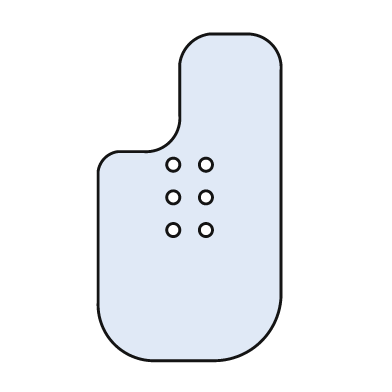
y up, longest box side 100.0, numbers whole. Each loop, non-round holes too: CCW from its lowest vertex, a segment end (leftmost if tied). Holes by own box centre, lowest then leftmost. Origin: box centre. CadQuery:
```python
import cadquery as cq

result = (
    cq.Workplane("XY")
    .moveTo(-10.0, -50.0)
    .lineTo(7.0, -50.0)
    .threePointArc((22.0, -44.0), (28.0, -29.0))
    .lineTo(28.0, 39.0)
    .threePointArc((25.0, 47.0), (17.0, 50.0))
    .lineTo(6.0, 50.0)
    .threePointArc((0.0, 47.0), (-3.0, 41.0))
    .lineTo(-3.0, 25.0)
    .threePointArc((-6.0, 17.0), (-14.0, 14.0))
    .lineTo(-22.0, 14.0)
    .threePointArc((-26.0, 12.0), (-28.0, 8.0))
    .lineTo(-28.0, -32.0)
    .threePointArc((-23.0, -45.0), (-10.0, -50.0))
    .close()
    .moveTo(-5.0, -10.0)
    .circle(2.0)
    .moveTo(5.0, -10.0)
    .circle(2.0)
    .moveTo(-5.0, 0.0)
    .circle(2.0)
    .moveTo(5.0, 0.0)
    .circle(2.0)
    .moveTo(-5.0, 10.0)
    .circle(2.0)
    .moveTo(5.0, 10.0)
    .circle(2.0)
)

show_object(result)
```